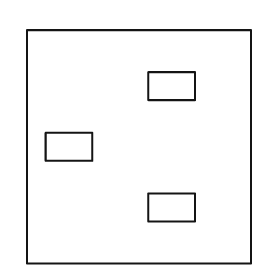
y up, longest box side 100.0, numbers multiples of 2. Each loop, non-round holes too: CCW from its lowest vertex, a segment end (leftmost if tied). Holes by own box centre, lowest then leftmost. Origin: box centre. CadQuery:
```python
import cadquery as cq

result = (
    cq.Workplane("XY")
    .moveTo(-48.0, -50.0)
    .lineTo(48.0, -50.0)
    .lineTo(48.0, 50.0)
    .lineTo(-48.0, 50.0)
    .close()
    .moveTo(4.0, -32.0)
    .lineTo(24.0, -32.0)
    .lineTo(24.0, -20.0)
    .lineTo(4.0, -20.0)
    .close()
    .moveTo(-40.0, -6.0)
    .lineTo(-20.0, -6.0)
    .lineTo(-20.0, 6.0)
    .lineTo(-40.0, 6.0)
    .close()
    .moveTo(4.0, 20.0)
    .lineTo(24.0, 20.0)
    .lineTo(24.0, 32.0)
    .lineTo(4.0, 32.0)
    .close()
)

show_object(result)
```